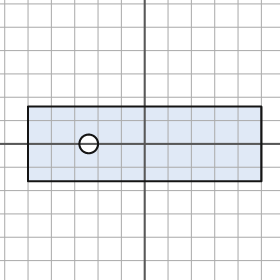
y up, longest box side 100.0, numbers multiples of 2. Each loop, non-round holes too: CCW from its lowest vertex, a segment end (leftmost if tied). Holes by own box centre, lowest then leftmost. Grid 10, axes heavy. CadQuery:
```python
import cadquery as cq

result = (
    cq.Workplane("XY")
    .moveTo(-50.0, -16.0)
    .lineTo(50.0, -16.0)
    .lineTo(50.0, 16.0)
    .lineTo(-50.0, 16.0)
    .close()
    .moveTo(-24.0, 0.0)
    .circle(4.0)
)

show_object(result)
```